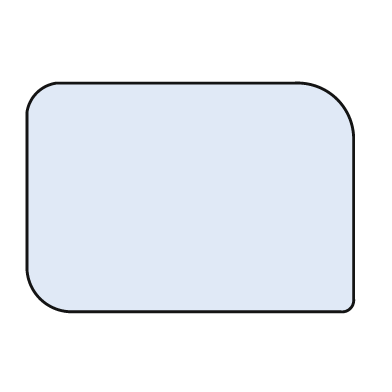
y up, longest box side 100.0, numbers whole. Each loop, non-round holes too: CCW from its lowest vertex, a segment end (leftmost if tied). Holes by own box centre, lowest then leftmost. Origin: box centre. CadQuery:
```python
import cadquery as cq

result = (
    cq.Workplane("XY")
    .moveTo(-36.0, -35.0)
    .lineTo(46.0, -35.0)
    .threePointArc((49.0, -34.0), (50.0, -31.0))
    .lineTo(50.0, 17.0)
    .threePointArc((45.0, 30.0), (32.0, 35.0))
    .lineTo(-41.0, 35.0)
    .threePointArc((-47.0, 32.0), (-50.0, 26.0))
    .lineTo(-50.0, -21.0)
    .threePointArc((-46.0, -31.0), (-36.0, -35.0))
    .close()
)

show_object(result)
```